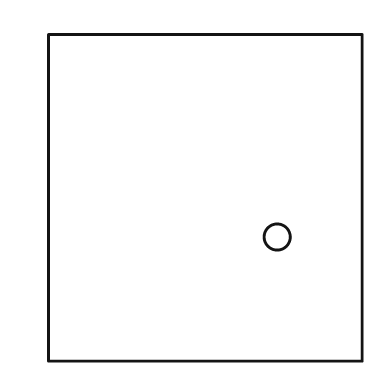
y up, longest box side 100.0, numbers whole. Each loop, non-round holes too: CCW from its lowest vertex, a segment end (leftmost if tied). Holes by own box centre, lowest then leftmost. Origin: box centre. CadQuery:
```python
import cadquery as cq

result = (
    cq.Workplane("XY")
    .moveTo(-48.0, -50.0)
    .lineTo(48.0, -50.0)
    .lineTo(48.0, 50.0)
    .lineTo(-48.0, 50.0)
    .close()
    .moveTo(22.0, -12.0)
    .circle(4.0)
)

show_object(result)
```